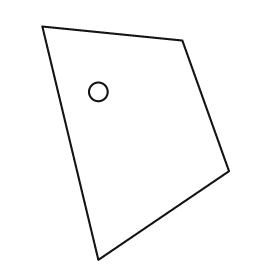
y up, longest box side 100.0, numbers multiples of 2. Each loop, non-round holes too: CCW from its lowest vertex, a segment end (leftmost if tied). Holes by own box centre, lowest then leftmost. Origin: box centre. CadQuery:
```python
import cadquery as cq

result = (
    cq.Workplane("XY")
    .moveTo(-16.0, -50.0)
    .lineTo(40.0, -12.0)
    .lineTo(20.0, 44.0)
    .lineTo(-40.0, 50.0)
    .close()
    .moveTo(-16.0, 22.0)
    .circle(4.0)
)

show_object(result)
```